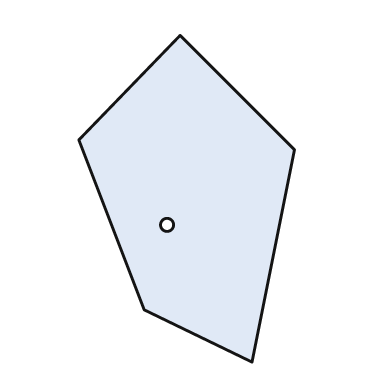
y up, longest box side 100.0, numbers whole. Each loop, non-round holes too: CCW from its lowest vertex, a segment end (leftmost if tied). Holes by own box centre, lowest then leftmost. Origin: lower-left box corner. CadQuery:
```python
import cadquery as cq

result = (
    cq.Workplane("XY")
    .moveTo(53.0, 0.0)
    .lineTo(66.0, 65.0)
    .lineTo(31.0, 100.0)
    .lineTo(0.0, 68.0)
    .lineTo(20.0, 16.0)
    .close()
    .moveTo(27.0, 42.0)
    .circle(2.0)
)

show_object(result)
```